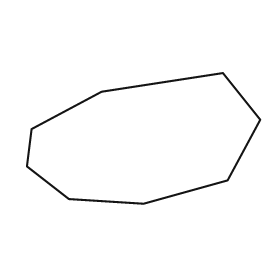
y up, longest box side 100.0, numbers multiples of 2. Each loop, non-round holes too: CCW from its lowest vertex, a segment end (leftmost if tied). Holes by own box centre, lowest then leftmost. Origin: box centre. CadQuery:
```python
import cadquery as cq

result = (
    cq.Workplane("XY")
    .moveTo(0.0, -28.0)
    .lineTo(36.0, -18.0)
    .lineTo(50.0, 8.0)
    .lineTo(34.0, 28.0)
    .lineTo(-18.0, 20.0)
    .lineTo(-48.0, 4.0)
    .lineTo(-50.0, -12.0)
    .lineTo(-32.0, -26.0)
    .close()
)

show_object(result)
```